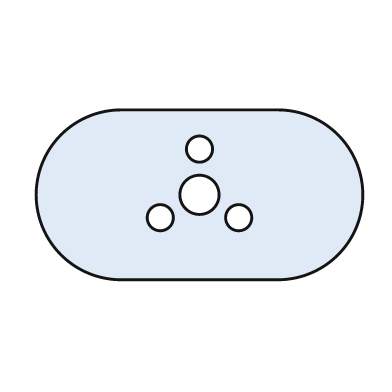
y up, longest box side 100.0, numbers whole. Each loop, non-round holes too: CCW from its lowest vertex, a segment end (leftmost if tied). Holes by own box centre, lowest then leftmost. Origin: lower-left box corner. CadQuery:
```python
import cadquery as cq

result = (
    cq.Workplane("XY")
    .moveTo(26.0, 0.0)
    .lineTo(74.0, 0.0)
    .threePointArc((100.0, 26.0), (74.0, 52.0))
    .lineTo(26.0, 52.0)
    .threePointArc((0.0, 26.0), (26.0, 0.0))
    .close()
    .moveTo(38.0, 19.0)
    .circle(4.0)
    .moveTo(62.0, 19.0)
    .circle(4.0)
    .moveTo(50.0, 26.0)
    .circle(6.0)
    .moveTo(50.0, 40.0)
    .circle(4.0)
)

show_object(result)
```